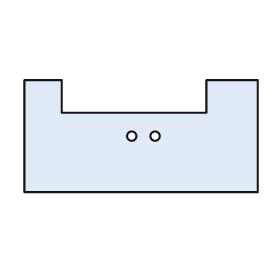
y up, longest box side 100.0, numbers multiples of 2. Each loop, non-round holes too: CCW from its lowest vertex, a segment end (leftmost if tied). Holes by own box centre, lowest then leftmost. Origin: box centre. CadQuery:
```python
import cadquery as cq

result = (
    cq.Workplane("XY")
    .moveTo(-50.0, -24.0)
    .lineTo(50.0, -24.0)
    .lineTo(50.0, 24.0)
    .lineTo(28.0, 24.0)
    .lineTo(28.0, 10.0)
    .lineTo(-34.0, 10.0)
    .lineTo(-34.0, 24.0)
    .lineTo(-50.0, 24.0)
    .close()
    .moveTo(-4.0, 0.0)
    .circle(2.0)
    .moveTo(6.0, 0.0)
    .circle(2.0)
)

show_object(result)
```